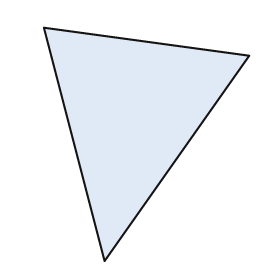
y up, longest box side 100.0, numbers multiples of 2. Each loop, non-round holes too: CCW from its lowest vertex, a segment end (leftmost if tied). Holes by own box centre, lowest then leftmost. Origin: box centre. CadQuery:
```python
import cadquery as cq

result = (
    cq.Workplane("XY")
    .moveTo(-18.0, -50.0)
    .lineTo(44.0, 38.0)
    .lineTo(-44.0, 50.0)
    .close()
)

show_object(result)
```